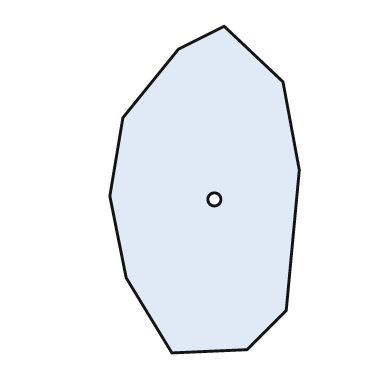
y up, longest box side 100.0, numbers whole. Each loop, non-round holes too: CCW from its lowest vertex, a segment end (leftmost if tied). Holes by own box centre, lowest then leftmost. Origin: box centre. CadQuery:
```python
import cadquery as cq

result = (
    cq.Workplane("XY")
    .moveTo(-10.0, -50.0)
    .lineTo(13.0, -49.0)
    .lineTo(25.0, -37.0)
    .lineTo(29.0, 6.0)
    .lineTo(24.0, 33.0)
    .lineTo(6.0, 50.0)
    .lineTo(-8.0, 43.0)
    .lineTo(-25.0, 22.0)
    .lineTo(-29.0, -2.0)
    .lineTo(-24.0, -27.0)
    .close()
    .moveTo(3.0, -3.0)
    .circle(2.0)
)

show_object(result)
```